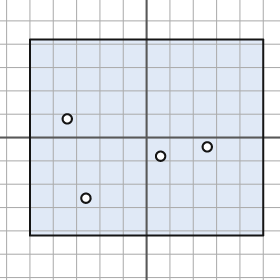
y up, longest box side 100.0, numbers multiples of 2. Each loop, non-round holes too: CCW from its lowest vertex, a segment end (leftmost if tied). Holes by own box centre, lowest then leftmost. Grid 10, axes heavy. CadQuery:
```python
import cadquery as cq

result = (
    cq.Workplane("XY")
    .moveTo(-50.0, -42.0)
    .lineTo(50.0, -42.0)
    .lineTo(50.0, 42.0)
    .lineTo(-50.0, 42.0)
    .close()
    .moveTo(-26.0, -26.0)
    .circle(2.0)
    .moveTo(6.0, -8.0)
    .circle(2.0)
    .moveTo(26.0, -4.0)
    .circle(2.0)
    .moveTo(-34.0, 8.0)
    .circle(2.0)
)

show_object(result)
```